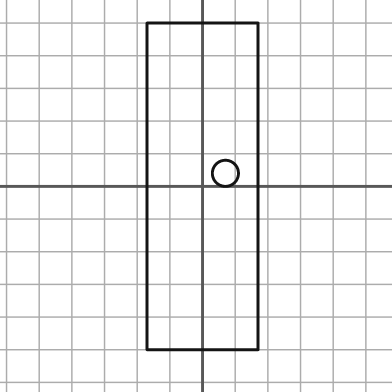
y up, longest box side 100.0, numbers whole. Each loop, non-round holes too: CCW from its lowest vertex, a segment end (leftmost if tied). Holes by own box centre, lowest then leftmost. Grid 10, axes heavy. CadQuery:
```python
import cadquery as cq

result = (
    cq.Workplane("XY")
    .moveTo(-17.0, -50.0)
    .lineTo(17.0, -50.0)
    .lineTo(17.0, 50.0)
    .lineTo(-17.0, 50.0)
    .close()
    .moveTo(7.0, 4.0)
    .circle(4.0)
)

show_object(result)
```